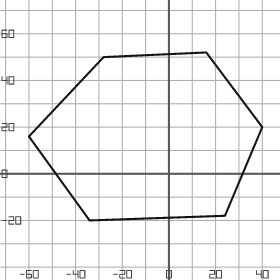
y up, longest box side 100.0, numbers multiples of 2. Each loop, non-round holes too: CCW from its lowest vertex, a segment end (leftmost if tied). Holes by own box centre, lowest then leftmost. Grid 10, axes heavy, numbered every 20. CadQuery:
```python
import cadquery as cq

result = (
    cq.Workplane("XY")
    .moveTo(-34.0, -20.0)
    .lineTo(24.0, -18.0)
    .lineTo(40.0, 20.0)
    .lineTo(16.0, 52.0)
    .lineTo(-28.0, 50.0)
    .lineTo(-60.0, 16.0)
    .close()
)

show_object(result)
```